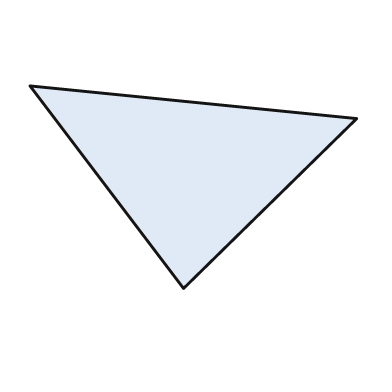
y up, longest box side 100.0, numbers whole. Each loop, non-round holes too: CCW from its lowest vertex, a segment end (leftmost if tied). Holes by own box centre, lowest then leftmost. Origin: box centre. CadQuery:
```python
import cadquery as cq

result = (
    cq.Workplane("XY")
    .moveTo(-3.0, -31.0)
    .lineTo(50.0, 21.0)
    .lineTo(-50.0, 31.0)
    .close()
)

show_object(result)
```